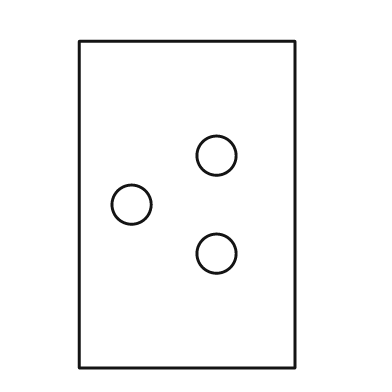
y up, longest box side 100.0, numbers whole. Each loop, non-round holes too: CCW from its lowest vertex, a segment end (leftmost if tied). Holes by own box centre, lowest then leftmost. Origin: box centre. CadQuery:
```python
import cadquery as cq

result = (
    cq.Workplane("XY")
    .moveTo(-33.0, -50.0)
    .lineTo(33.0, -50.0)
    .lineTo(33.0, 50.0)
    .lineTo(-33.0, 50.0)
    .close()
    .moveTo(9.0, -15.0)
    .circle(6.0)
    .moveTo(-17.0, 0.0)
    .circle(6.0)
    .moveTo(9.0, 15.0)
    .circle(6.0)
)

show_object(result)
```